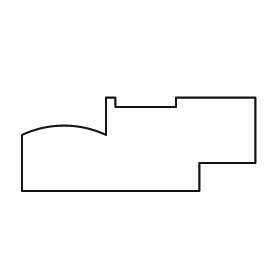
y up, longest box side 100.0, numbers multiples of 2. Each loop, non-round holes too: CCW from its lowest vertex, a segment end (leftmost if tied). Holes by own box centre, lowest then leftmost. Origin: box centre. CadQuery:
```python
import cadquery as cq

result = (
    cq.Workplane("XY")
    .moveTo(-50.0, -20.0)
    .lineTo(26.0, -20.0)
    .lineTo(26.0, -8.0)
    .lineTo(50.0, -8.0)
    .lineTo(50.0, 20.0)
    .lineTo(16.0, 20.0)
    .lineTo(16.0, 16.0)
    .lineTo(-10.0, 16.0)
    .lineTo(-10.0, 20.0)
    .lineTo(-14.0, 20.0)
    .lineTo(-14.0, 4.0)
    .threePointArc((-32.0, 8.0), (-50.0, 4.0))
    .close()
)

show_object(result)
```